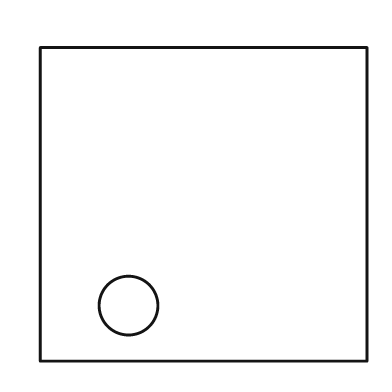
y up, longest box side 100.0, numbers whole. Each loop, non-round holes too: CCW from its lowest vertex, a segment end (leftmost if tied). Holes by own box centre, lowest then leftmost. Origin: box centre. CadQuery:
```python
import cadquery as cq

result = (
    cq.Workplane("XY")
    .moveTo(-50.0, -48.0)
    .lineTo(50.0, -48.0)
    .lineTo(50.0, 48.0)
    .lineTo(-50.0, 48.0)
    .close()
    .moveTo(-23.0, -31.0)
    .circle(9.0)
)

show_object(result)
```